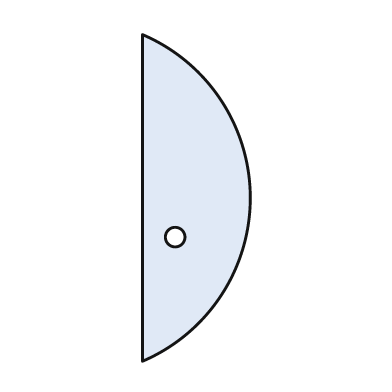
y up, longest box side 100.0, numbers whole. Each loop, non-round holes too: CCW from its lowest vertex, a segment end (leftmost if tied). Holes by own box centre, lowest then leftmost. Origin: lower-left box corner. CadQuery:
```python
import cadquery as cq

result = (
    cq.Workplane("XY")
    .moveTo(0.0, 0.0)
    .threePointArc((33.0, 50.0), (0.0, 100.0))
    .close()
    .moveTo(10.0, 38.0)
    .circle(3.0)
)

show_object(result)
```